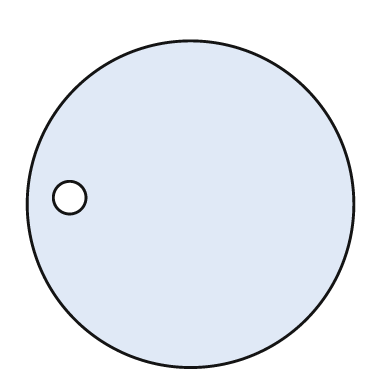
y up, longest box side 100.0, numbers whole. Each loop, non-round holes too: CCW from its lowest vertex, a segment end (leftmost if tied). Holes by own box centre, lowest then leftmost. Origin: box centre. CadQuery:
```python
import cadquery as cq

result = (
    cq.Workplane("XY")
    .moveTo(0.0, 0.0)
    .circle(50.0)
    .moveTo(-37.0, 2.0)
    .circle(5.0)
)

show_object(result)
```